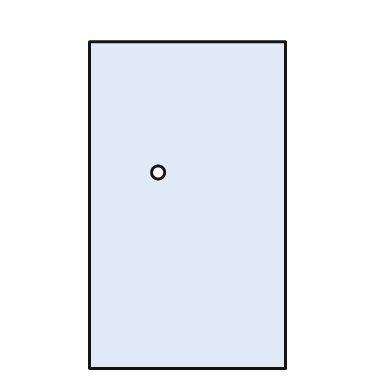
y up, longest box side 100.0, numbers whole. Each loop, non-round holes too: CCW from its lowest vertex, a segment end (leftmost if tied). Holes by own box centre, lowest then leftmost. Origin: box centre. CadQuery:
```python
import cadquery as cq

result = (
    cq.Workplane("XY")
    .moveTo(-30.0, -50.0)
    .lineTo(30.0, -50.0)
    .lineTo(30.0, 50.0)
    .lineTo(-30.0, 50.0)
    .close()
    .moveTo(-9.0, 10.0)
    .circle(2.0)
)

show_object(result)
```